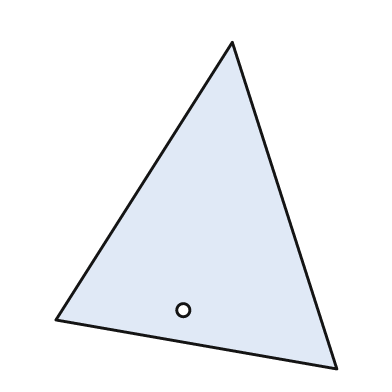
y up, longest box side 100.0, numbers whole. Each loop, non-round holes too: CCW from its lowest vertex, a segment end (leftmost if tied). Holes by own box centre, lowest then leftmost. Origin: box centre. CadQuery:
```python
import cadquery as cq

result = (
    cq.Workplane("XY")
    .moveTo(43.0, -50.0)
    .lineTo(11.0, 50.0)
    .lineTo(-43.0, -35.0)
    .close()
    .moveTo(-4.0, -32.0)
    .circle(2.0)
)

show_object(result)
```